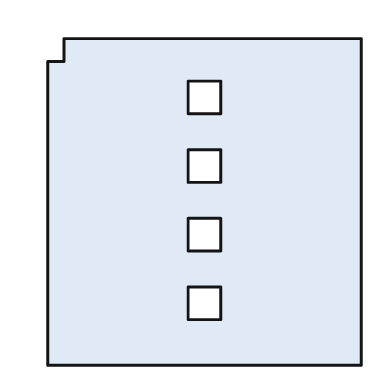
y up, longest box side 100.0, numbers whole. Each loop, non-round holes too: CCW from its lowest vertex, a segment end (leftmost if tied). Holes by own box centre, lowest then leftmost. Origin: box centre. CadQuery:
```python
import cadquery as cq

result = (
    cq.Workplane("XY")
    .moveTo(-48.0, -50.0)
    .lineTo(48.0, -50.0)
    .lineTo(48.0, 50.0)
    .lineTo(-43.0, 50.0)
    .lineTo(-43.0, 43.0)
    .lineTo(-48.0, 43.0)
    .close()
    .moveTo(-5.0, -36.0)
    .lineTo(5.0, -36.0)
    .lineTo(5.0, -26.0)
    .lineTo(-5.0, -26.0)
    .close()
    .moveTo(-5.0, -15.0)
    .lineTo(5.0, -15.0)
    .lineTo(5.0, -5.0)
    .lineTo(-5.0, -5.0)
    .close()
    .moveTo(-5.0, 6.0)
    .lineTo(5.0, 6.0)
    .lineTo(5.0, 16.0)
    .lineTo(-5.0, 16.0)
    .close()
    .moveTo(-5.0, 27.0)
    .lineTo(5.0, 27.0)
    .lineTo(5.0, 37.0)
    .lineTo(-5.0, 37.0)
    .close()
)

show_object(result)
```